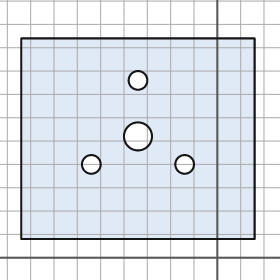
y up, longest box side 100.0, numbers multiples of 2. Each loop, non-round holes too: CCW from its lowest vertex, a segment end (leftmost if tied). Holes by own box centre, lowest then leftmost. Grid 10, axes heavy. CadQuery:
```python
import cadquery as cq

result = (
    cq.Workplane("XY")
    .moveTo(-84.0, 8.0)
    .lineTo(16.0, 8.0)
    .lineTo(16.0, 94.0)
    .lineTo(-84.0, 94.0)
    .close()
    .moveTo(-54.0, 40.0)
    .circle(4.0)
    .moveTo(-14.0, 40.0)
    .circle(4.0)
    .moveTo(-34.0, 52.0)
    .circle(6.0)
    .moveTo(-34.0, 76.0)
    .circle(4.0)
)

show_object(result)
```